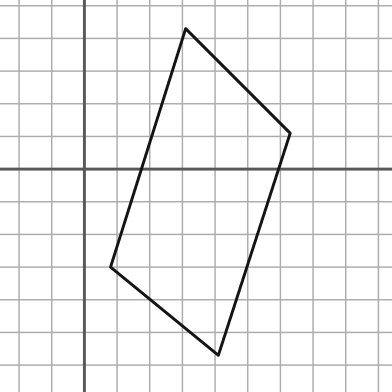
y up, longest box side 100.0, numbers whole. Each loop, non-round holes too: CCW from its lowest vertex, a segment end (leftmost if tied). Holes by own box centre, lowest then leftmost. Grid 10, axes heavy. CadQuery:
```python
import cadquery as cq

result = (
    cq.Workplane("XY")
    .moveTo(41.0, -57.0)
    .lineTo(63.0, 11.0)
    .lineTo(31.0, 43.0)
    .lineTo(8.0, -30.0)
    .close()
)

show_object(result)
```